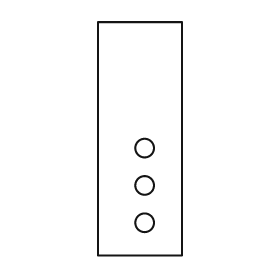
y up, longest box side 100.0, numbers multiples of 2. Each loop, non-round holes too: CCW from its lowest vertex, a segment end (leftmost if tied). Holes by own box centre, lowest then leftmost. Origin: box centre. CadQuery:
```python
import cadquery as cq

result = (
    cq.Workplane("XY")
    .moveTo(-18.0, -50.0)
    .lineTo(18.0, -50.0)
    .lineTo(18.0, 50.0)
    .lineTo(-18.0, 50.0)
    .close()
    .moveTo(2.0, -36.0)
    .circle(4.0)
    .moveTo(2.0, -20.0)
    .circle(4.0)
    .moveTo(2.0, -4.0)
    .circle(4.0)
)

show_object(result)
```